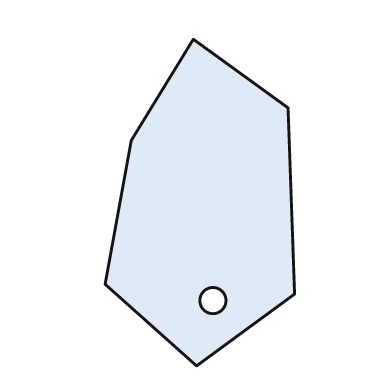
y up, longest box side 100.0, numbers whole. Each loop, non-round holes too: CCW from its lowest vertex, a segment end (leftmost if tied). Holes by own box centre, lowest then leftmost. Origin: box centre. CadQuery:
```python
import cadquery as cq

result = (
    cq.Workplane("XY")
    .moveTo(-1.0, -50.0)
    .lineTo(29.0, -28.0)
    .lineTo(27.0, 29.0)
    .lineTo(-2.0, 50.0)
    .lineTo(-21.0, 19.0)
    .lineTo(-29.0, -25.0)
    .close()
    .moveTo(4.0, -30.0)
    .circle(4.0)
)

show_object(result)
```